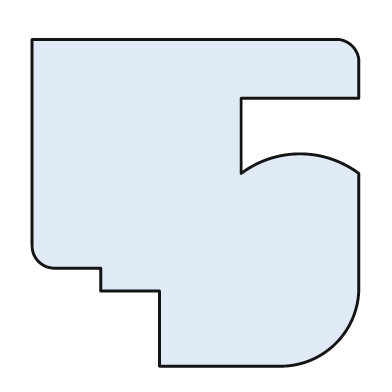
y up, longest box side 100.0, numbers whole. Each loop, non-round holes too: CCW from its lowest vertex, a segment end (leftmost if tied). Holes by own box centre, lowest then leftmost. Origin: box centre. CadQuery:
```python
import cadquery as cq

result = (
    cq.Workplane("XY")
    .moveTo(-11.0, -50.0)
    .lineTo(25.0, -50.0)
    .threePointArc((43.0, -43.0), (50.0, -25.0))
    .lineTo(50.0, 9.0)
    .threePointArc((32.0, 15.0), (14.0, 9.0))
    .lineTo(14.0, 32.0)
    .lineTo(50.0, 32.0)
    .lineTo(50.0, 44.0)
    .threePointArc((48.0, 48.0), (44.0, 50.0))
    .lineTo(-50.0, 50.0)
    .lineTo(-50.0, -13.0)
    .threePointArc((-48.0, -18.0), (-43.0, -20.0))
    .lineTo(-29.0, -20.0)
    .lineTo(-29.0, -27.0)
    .lineTo(-11.0, -27.0)
    .close()
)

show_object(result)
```